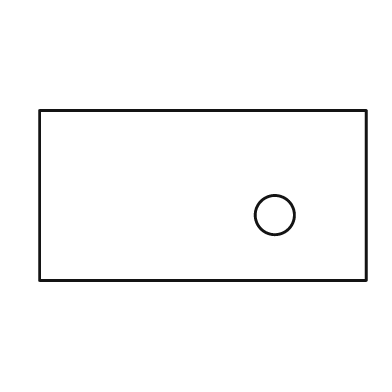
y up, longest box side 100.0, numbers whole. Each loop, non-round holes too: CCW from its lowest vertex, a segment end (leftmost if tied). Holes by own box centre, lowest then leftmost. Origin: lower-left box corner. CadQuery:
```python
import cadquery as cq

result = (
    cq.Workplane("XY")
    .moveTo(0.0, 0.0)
    .lineTo(100.0, 0.0)
    .lineTo(100.0, 52.0)
    .lineTo(0.0, 52.0)
    .close()
    .moveTo(72.0, 20.0)
    .circle(6.0)
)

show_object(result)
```